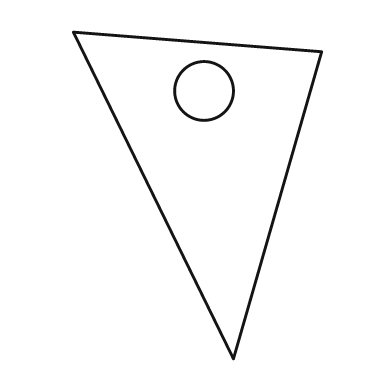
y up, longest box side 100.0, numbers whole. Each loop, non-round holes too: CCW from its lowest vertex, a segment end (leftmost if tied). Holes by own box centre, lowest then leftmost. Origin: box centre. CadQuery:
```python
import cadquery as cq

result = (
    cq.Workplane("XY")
    .moveTo(11.0, -50.0)
    .lineTo(38.0, 44.0)
    .lineTo(-38.0, 50.0)
    .close()
    .moveTo(2.0, 32.0)
    .circle(9.0)
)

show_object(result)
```